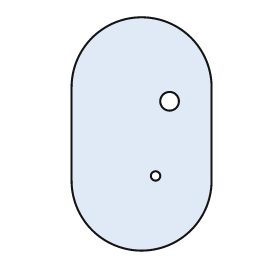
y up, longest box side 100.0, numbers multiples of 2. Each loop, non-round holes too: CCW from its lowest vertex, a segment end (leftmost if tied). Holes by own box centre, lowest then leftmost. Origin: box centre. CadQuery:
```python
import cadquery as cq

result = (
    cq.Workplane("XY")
    .moveTo(-30.0, -20.0)
    .threePointArc((0.0, -50.0), (30.0, -20.0))
    .lineTo(30.0, 20.0)
    .threePointArc((0.0, 50.0), (-30.0, 20.0))
    .close()
    .moveTo(6.0, -18.0)
    .circle(2.0)
    .moveTo(12.0, 14.0)
    .circle(4.0)
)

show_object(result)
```